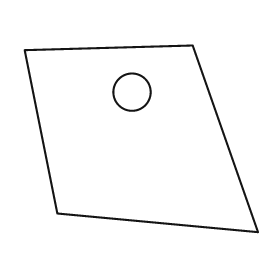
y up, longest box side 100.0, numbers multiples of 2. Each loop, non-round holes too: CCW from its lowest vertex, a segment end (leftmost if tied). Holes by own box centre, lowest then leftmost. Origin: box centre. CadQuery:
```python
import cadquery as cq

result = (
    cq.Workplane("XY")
    .moveTo(50.0, -40.0)
    .lineTo(22.0, 40.0)
    .lineTo(-50.0, 38.0)
    .lineTo(-36.0, -32.0)
    .close()
    .moveTo(-4.0, 20.0)
    .circle(8.0)
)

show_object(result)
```